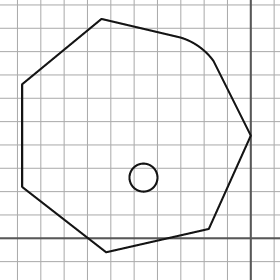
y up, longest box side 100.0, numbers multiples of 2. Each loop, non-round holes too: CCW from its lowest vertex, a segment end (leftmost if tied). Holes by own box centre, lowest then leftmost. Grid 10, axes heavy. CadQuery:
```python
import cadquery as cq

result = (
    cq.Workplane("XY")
    .moveTo(-62.0, -6.0)
    .lineTo(-18.0, 4.0)
    .lineTo(0.0, 44.0)
    .lineTo(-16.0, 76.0)
    .threePointArc((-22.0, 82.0), (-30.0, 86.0))
    .lineTo(-64.0, 94.0)
    .lineTo(-98.0, 66.0)
    .lineTo(-98.0, 22.0)
    .close()
    .moveTo(-46.0, 26.0)
    .circle(6.0)
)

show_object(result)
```